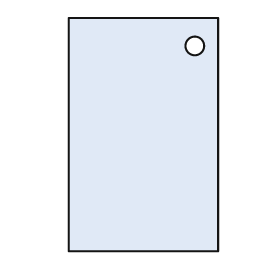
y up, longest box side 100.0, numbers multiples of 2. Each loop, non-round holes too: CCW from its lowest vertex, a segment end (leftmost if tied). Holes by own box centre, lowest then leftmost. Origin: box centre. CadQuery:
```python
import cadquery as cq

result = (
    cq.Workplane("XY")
    .moveTo(-32.0, -50.0)
    .lineTo(32.0, -50.0)
    .lineTo(32.0, 50.0)
    .lineTo(-32.0, 50.0)
    .close()
    .moveTo(22.0, 38.0)
    .circle(4.0)
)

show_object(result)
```